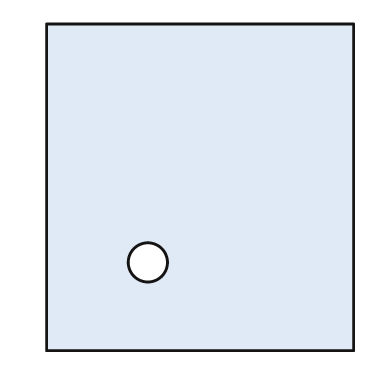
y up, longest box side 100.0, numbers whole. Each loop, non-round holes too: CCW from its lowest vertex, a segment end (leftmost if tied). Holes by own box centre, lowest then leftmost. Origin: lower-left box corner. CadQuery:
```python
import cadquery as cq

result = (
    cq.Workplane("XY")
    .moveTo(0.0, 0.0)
    .lineTo(94.0, 0.0)
    .lineTo(94.0, 100.0)
    .lineTo(0.0, 100.0)
    .close()
    .moveTo(31.0, 27.0)
    .circle(6.0)
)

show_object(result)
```